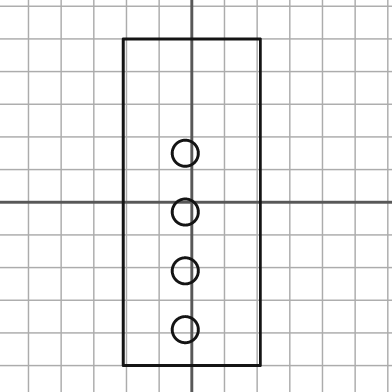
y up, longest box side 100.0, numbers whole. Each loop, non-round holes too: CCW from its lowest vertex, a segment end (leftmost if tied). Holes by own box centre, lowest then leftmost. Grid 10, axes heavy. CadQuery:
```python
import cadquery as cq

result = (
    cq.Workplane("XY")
    .moveTo(-21.0, -50.0)
    .lineTo(21.0, -50.0)
    .lineTo(21.0, 50.0)
    .lineTo(-21.0, 50.0)
    .close()
    .moveTo(-2.0, -39.0)
    .circle(4.0)
    .moveTo(-2.0, -21.0)
    .circle(4.0)
    .moveTo(-2.0, -3.0)
    .circle(4.0)
    .moveTo(-2.0, 15.0)
    .circle(4.0)
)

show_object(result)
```